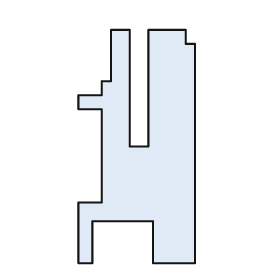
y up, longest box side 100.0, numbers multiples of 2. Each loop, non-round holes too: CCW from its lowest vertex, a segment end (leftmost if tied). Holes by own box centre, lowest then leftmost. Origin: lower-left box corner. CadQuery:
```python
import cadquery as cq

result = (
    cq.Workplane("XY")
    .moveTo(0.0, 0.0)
    .lineTo(6.0, 0.0)
    .lineTo(6.0, 18.0)
    .lineTo(32.0, 18.0)
    .lineTo(32.0, 0.0)
    .lineTo(50.0, 0.0)
    .lineTo(50.0, 94.0)
    .lineTo(46.0, 94.0)
    .lineTo(46.0, 100.0)
    .lineTo(30.0, 100.0)
    .lineTo(30.0, 50.0)
    .lineTo(22.0, 50.0)
    .lineTo(22.0, 100.0)
    .lineTo(14.0, 100.0)
    .lineTo(14.0, 78.0)
    .lineTo(10.0, 78.0)
    .lineTo(10.0, 72.0)
    .lineTo(0.0, 72.0)
    .lineTo(0.0, 66.0)
    .lineTo(10.0, 66.0)
    .lineTo(10.0, 26.0)
    .lineTo(0.0, 26.0)
    .close()
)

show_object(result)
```